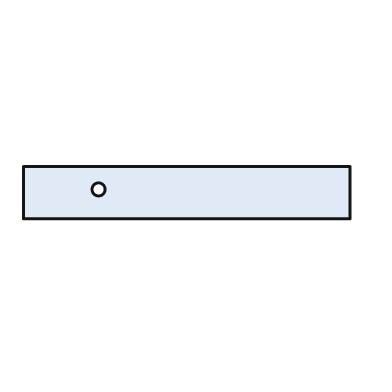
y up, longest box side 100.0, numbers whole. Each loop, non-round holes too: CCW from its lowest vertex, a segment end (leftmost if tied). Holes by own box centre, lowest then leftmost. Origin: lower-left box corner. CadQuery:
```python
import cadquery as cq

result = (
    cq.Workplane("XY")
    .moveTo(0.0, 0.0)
    .lineTo(100.0, 0.0)
    .lineTo(100.0, 16.0)
    .lineTo(0.0, 16.0)
    .close()
    .moveTo(23.0, 9.0)
    .circle(2.0)
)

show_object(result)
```